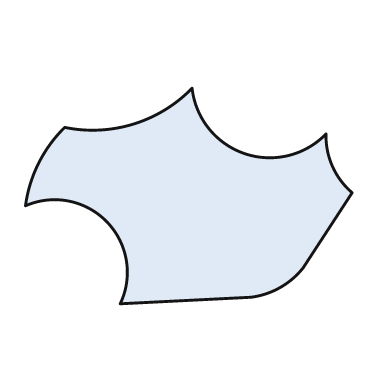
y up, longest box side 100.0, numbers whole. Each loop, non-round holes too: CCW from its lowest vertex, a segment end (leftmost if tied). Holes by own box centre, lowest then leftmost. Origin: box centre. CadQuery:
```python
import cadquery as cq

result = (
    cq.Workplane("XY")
    .moveTo(-21.0, -33.0)
    .lineTo(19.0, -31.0)
    .threePointArc((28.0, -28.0), (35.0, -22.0))
    .lineTo(50.0, 1.0)
    .threePointArc((44.0, 9.0), (42.0, 19.0))
    .threePointArc((17.0, 13.0), (1.0, 33.0))
    .threePointArc((-17.0, 22.0), (-38.0, 21.0))
    .threePointArc((-46.0, 10.0), (-50.0, -3.0))
    .threePointArc((-25.0, -8.0), (-21.0, -33.0))
    .close()
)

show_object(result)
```